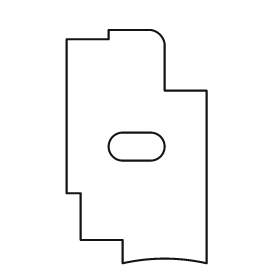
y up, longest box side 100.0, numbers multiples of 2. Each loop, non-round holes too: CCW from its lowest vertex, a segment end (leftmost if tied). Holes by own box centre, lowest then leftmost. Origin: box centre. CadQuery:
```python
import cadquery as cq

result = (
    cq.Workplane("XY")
    .moveTo(-6.0, -50.0)
    .threePointArc((12.0, -48.0), (30.0, -50.0))
    .lineTo(30.0, 24.0)
    .lineTo(12.0, 24.0)
    .lineTo(12.0, 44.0)
    .threePointArc((10.0, 48.0), (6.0, 50.0))
    .lineTo(-12.0, 50.0)
    .lineTo(-12.0, 46.0)
    .lineTo(-30.0, 46.0)
    .lineTo(-30.0, -20.0)
    .lineTo(-24.0, -20.0)
    .lineTo(-24.0, -40.0)
    .lineTo(-6.0, -40.0)
    .close()
    .moveTo(-6.0, -6.0)
    .lineTo(6.0, -6.0)
    .threePointArc((12.0, 0.0), (6.0, 6.0))
    .lineTo(-6.0, 6.0)
    .threePointArc((-12.0, 0.0), (-6.0, -6.0))
    .close()
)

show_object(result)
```